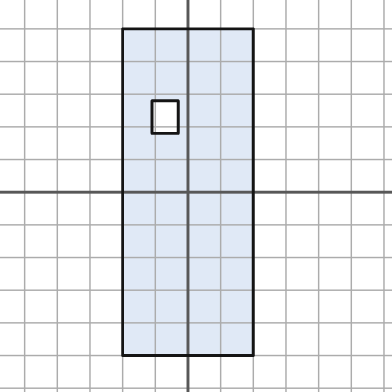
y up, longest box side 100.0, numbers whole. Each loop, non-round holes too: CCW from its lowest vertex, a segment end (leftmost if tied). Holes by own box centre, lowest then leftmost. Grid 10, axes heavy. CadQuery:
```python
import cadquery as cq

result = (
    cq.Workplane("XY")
    .moveTo(-20.0, -50.0)
    .lineTo(20.0, -50.0)
    .lineTo(20.0, 50.0)
    .lineTo(-20.0, 50.0)
    .close()
    .moveTo(-11.0, 18.0)
    .lineTo(-3.0, 18.0)
    .lineTo(-3.0, 28.0)
    .lineTo(-11.0, 28.0)
    .close()
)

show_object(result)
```